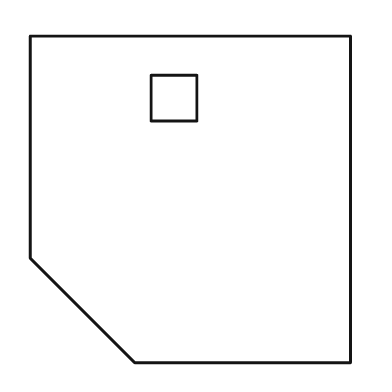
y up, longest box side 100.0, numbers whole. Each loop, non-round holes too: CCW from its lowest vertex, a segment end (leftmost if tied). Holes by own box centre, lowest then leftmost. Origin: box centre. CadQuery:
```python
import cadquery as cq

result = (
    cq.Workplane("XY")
    .moveTo(-17.0, -50.0)
    .lineTo(49.0, -50.0)
    .lineTo(49.0, 50.0)
    .lineTo(-49.0, 50.0)
    .lineTo(-49.0, -18.0)
    .close()
    .moveTo(-12.0, 24.0)
    .lineTo(2.0, 24.0)
    .lineTo(2.0, 38.0)
    .lineTo(-12.0, 38.0)
    .close()
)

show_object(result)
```